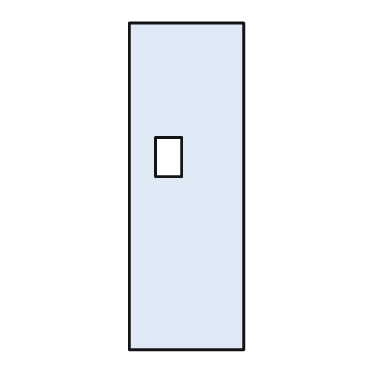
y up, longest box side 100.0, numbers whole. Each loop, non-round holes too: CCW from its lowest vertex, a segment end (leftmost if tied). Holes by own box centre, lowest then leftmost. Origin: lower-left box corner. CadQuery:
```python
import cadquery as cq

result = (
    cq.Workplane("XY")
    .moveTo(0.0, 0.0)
    .lineTo(35.0, 0.0)
    .lineTo(35.0, 100.0)
    .lineTo(0.0, 100.0)
    .close()
    .moveTo(8.0, 53.0)
    .lineTo(16.0, 53.0)
    .lineTo(16.0, 65.0)
    .lineTo(8.0, 65.0)
    .close()
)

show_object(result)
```